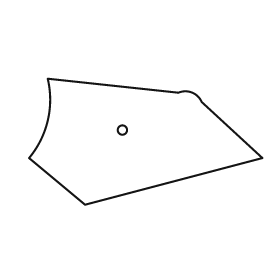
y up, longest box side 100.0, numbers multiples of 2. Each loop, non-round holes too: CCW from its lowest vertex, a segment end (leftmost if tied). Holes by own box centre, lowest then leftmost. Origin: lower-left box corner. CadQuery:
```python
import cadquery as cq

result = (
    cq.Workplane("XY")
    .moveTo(24.0, 0.0)
    .lineTo(100.0, 20.0)
    .lineTo(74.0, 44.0)
    .threePointArc((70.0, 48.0), (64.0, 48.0))
    .lineTo(8.0, 54.0)
    .threePointArc((8.0, 36.0), (0.0, 20.0))
    .close()
    .moveTo(40.0, 32.0)
    .circle(2.0)
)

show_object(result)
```